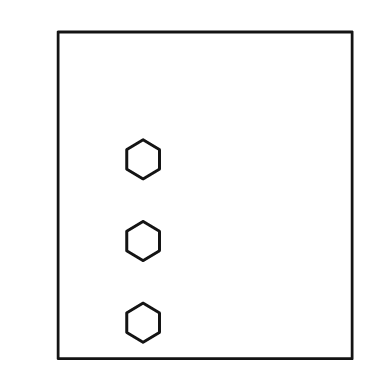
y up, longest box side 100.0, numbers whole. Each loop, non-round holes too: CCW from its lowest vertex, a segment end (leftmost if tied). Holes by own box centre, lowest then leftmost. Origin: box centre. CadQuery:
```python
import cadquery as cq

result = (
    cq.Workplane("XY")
    .moveTo(-45.0, -50.0)
    .lineTo(45.0, -50.0)
    .lineTo(45.0, 50.0)
    .lineTo(-45.0, 50.0)
    .close()
    .moveTo(-19.0, -45.0)
    .lineTo(-14.0, -42.0)
    .lineTo(-14.0, -36.0)
    .lineTo(-19.0, -33.0)
    .lineTo(-24.0, -36.0)
    .lineTo(-24.0, -42.0)
    .close()
    .moveTo(-19.0, -20.0)
    .lineTo(-14.0, -17.0)
    .lineTo(-14.0, -11.0)
    .lineTo(-19.0, -8.0)
    .lineTo(-24.0, -11.0)
    .lineTo(-24.0, -17.0)
    .close()
    .moveTo(-19.0, 5.0)
    .lineTo(-14.0, 8.0)
    .lineTo(-14.0, 14.0)
    .lineTo(-19.0, 17.0)
    .lineTo(-24.0, 14.0)
    .lineTo(-24.0, 8.0)
    .close()
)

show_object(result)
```